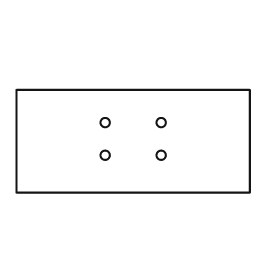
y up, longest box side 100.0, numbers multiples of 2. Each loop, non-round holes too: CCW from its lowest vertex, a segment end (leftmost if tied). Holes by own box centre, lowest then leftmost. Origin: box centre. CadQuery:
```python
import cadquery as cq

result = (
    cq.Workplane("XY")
    .moveTo(-50.0, -22.0)
    .lineTo(50.0, -22.0)
    .lineTo(50.0, 22.0)
    .lineTo(-50.0, 22.0)
    .close()
    .moveTo(-12.0, -6.0)
    .circle(2.0)
    .moveTo(12.0, -6.0)
    .circle(2.0)
    .moveTo(-12.0, 8.0)
    .circle(2.0)
    .moveTo(12.0, 8.0)
    .circle(2.0)
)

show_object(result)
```